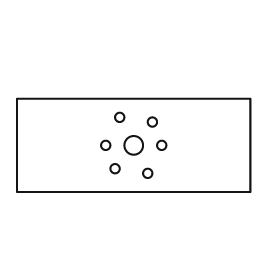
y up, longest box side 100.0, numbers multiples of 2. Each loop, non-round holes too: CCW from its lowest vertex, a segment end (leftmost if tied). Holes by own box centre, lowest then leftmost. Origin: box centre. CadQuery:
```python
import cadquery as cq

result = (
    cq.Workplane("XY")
    .moveTo(-50.0, -20.0)
    .lineTo(50.0, -20.0)
    .lineTo(50.0, 20.0)
    .lineTo(-50.0, 20.0)
    .close()
    .moveTo(6.0, -12.0)
    .circle(2.0)
    .moveTo(-8.0, -10.0)
    .circle(2.0)
    .moveTo(-12.0, 0.0)
    .circle(2.0)
    .moveTo(0.0, 0.0)
    .circle(4.0)
    .moveTo(12.0, 0.0)
    .circle(2.0)
    .moveTo(8.0, 10.0)
    .circle(2.0)
    .moveTo(-6.0, 12.0)
    .circle(2.0)
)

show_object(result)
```